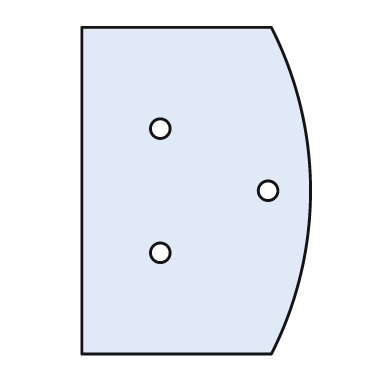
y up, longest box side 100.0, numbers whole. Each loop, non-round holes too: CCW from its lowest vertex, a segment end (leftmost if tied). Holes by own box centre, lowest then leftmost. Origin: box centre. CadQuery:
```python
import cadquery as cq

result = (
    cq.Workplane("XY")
    .moveTo(-35.0, -50.0)
    .lineTo(23.0, -50.0)
    .threePointArc((35.0, 0.0), (23.0, 50.0))
    .lineTo(-35.0, 50.0)
    .close()
    .moveTo(-11.0, -19.0)
    .circle(3.0)
    .moveTo(22.0, 0.0)
    .circle(3.0)
    .moveTo(-11.0, 19.0)
    .circle(3.0)
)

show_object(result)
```